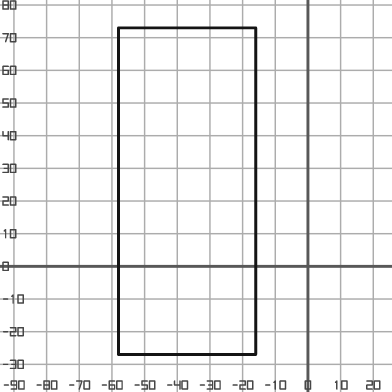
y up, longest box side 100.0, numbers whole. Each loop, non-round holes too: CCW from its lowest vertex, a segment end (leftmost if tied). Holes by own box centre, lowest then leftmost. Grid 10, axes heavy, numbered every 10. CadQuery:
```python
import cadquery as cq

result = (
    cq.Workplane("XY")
    .moveTo(-58.0, -27.0)
    .lineTo(-16.0, -27.0)
    .lineTo(-16.0, 73.0)
    .lineTo(-58.0, 73.0)
    .close()
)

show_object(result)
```